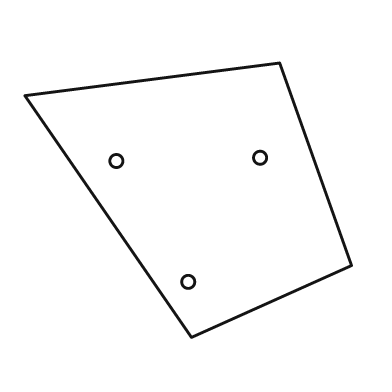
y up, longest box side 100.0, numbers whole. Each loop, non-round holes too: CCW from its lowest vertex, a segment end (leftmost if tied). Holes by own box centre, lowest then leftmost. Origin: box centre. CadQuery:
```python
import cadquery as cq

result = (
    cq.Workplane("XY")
    .moveTo(1.0, -42.0)
    .lineTo(50.0, -20.0)
    .lineTo(28.0, 42.0)
    .lineTo(-50.0, 32.0)
    .close()
    .moveTo(0.0, -25.0)
    .circle(2.0)
    .moveTo(-22.0, 12.0)
    .circle(2.0)
    .moveTo(22.0, 13.0)
    .circle(2.0)
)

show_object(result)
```